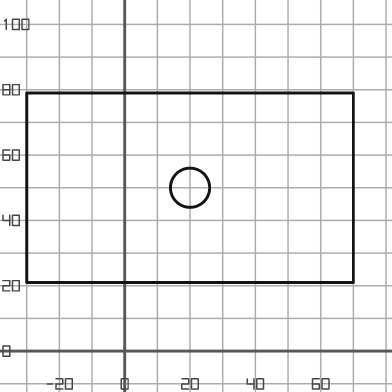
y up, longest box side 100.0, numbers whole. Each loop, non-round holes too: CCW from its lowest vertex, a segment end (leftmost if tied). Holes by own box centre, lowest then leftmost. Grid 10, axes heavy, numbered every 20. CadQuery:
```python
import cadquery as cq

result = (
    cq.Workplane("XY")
    .moveTo(-30.0, 21.0)
    .lineTo(70.0, 21.0)
    .lineTo(70.0, 79.0)
    .lineTo(-30.0, 79.0)
    .close()
    .moveTo(20.0, 50.0)
    .circle(6.0)
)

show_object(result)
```